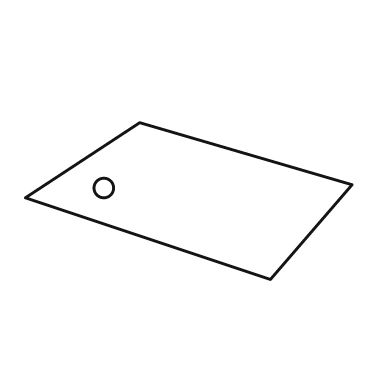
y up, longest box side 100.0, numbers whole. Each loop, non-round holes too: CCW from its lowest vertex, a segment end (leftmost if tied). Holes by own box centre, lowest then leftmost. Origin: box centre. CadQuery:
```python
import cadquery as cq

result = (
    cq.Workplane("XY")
    .moveTo(25.0, -24.0)
    .lineTo(50.0, 5.0)
    .lineTo(-15.0, 24.0)
    .lineTo(-50.0, 1.0)
    .close()
    .moveTo(-26.0, 4.0)
    .circle(3.0)
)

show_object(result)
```